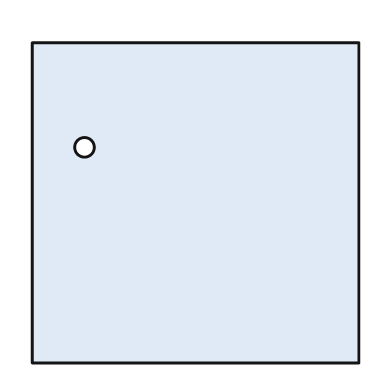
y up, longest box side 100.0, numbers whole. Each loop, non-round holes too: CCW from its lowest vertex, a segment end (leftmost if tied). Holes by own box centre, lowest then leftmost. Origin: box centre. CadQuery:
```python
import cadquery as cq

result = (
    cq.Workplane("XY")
    .moveTo(-50.0, -49.0)
    .lineTo(50.0, -49.0)
    .lineTo(50.0, 49.0)
    .lineTo(-50.0, 49.0)
    .close()
    .moveTo(-34.0, 17.0)
    .circle(3.0)
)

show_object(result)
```